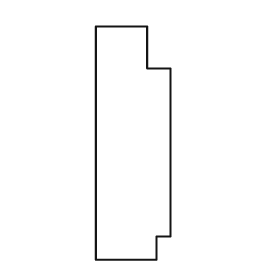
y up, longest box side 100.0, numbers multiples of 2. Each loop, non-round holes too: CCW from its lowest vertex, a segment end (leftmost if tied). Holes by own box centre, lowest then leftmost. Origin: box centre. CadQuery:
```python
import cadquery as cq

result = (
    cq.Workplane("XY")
    .moveTo(-16.0, -50.0)
    .lineTo(10.0, -50.0)
    .lineTo(10.0, -40.0)
    .lineTo(16.0, -40.0)
    .lineTo(16.0, 32.0)
    .lineTo(6.0, 32.0)
    .lineTo(6.0, 50.0)
    .lineTo(-16.0, 50.0)
    .close()
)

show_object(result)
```